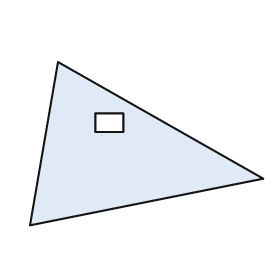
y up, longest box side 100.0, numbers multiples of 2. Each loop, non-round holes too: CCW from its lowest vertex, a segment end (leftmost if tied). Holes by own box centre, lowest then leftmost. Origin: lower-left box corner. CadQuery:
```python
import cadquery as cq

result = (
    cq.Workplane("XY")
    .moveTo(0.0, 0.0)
    .lineTo(100.0, 20.0)
    .lineTo(12.0, 70.0)
    .close()
    .moveTo(28.0, 40.0)
    .lineTo(40.0, 40.0)
    .lineTo(40.0, 48.0)
    .lineTo(28.0, 48.0)
    .close()
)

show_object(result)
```